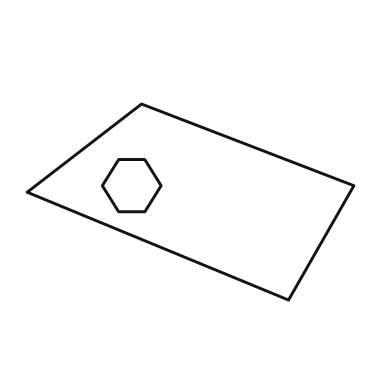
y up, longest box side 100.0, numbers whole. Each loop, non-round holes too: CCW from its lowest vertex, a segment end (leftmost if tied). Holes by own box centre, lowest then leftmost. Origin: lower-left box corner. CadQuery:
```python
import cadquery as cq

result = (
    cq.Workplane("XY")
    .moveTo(80.0, 0.0)
    .lineTo(100.0, 35.0)
    .lineTo(35.0, 60.0)
    .lineTo(0.0, 33.0)
    .close()
    .moveTo(28.0, 27.0)
    .lineTo(36.0, 27.0)
    .lineTo(41.0, 35.0)
    .lineTo(36.0, 43.0)
    .lineTo(28.0, 43.0)
    .lineTo(23.0, 35.0)
    .close()
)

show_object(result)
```